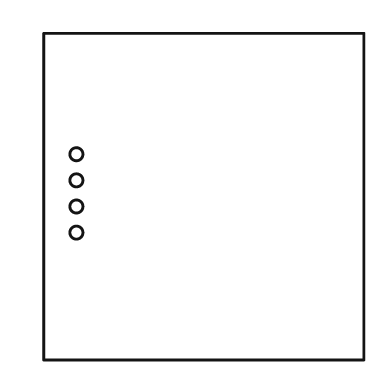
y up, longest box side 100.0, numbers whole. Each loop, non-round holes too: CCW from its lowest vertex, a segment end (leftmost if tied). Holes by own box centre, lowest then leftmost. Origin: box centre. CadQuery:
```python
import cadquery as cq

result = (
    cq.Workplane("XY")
    .moveTo(-49.0, -50.0)
    .lineTo(49.0, -50.0)
    .lineTo(49.0, 50.0)
    .lineTo(-49.0, 50.0)
    .close()
    .moveTo(-39.0, -11.0)
    .circle(2.0)
    .moveTo(-39.0, -3.0)
    .circle(2.0)
    .moveTo(-39.0, 5.0)
    .circle(2.0)
    .moveTo(-39.0, 13.0)
    .circle(2.0)
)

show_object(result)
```